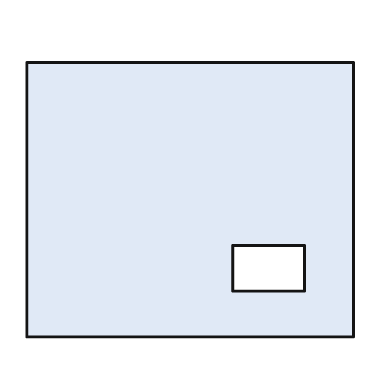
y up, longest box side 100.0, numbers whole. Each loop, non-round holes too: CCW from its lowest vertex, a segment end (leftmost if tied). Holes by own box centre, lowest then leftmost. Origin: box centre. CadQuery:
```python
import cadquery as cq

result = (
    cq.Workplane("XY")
    .moveTo(-50.0, -42.0)
    .lineTo(50.0, -42.0)
    .lineTo(50.0, 42.0)
    .lineTo(-50.0, 42.0)
    .close()
    .moveTo(13.0, -28.0)
    .lineTo(35.0, -28.0)
    .lineTo(35.0, -14.0)
    .lineTo(13.0, -14.0)
    .close()
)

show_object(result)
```